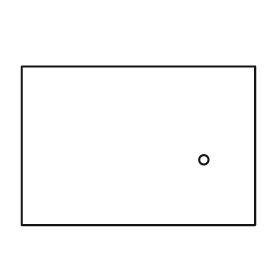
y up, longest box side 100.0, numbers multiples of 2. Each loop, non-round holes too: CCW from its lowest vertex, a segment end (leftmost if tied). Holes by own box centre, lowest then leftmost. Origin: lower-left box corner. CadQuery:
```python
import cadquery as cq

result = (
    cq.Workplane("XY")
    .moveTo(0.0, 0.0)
    .lineTo(100.0, 0.0)
    .lineTo(100.0, 68.0)
    .lineTo(0.0, 68.0)
    .close()
    .moveTo(78.0, 28.0)
    .circle(2.0)
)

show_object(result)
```